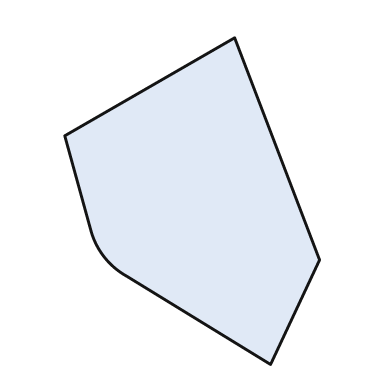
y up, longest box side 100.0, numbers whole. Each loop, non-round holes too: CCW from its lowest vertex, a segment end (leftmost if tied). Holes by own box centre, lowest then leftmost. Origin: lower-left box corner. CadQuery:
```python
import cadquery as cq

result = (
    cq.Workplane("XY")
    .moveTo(63.0, 0.0)
    .lineTo(78.0, 32.0)
    .lineTo(52.0, 100.0)
    .lineTo(0.0, 70.0)
    .lineTo(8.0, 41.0)
    .threePointArc((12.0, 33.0), (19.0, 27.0))
    .close()
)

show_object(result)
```